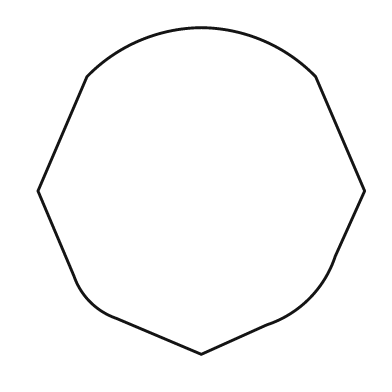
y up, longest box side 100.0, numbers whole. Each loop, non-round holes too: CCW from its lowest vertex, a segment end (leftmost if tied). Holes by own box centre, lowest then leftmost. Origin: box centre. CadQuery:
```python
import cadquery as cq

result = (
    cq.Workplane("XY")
    .moveTo(0.0, -50.0)
    .lineTo(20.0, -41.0)
    .threePointArc((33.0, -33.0), (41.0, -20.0))
    .lineTo(50.0, 0.0)
    .lineTo(35.0, 35.0)
    .threePointArc((19.0, 46.0), (0.0, 50.0))
    .threePointArc((-19.0, 46.0), (-35.0, 35.0))
    .lineTo(-50.0, 0.0)
    .lineTo(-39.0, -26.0)
    .threePointArc((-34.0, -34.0), (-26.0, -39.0))
    .close()
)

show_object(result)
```